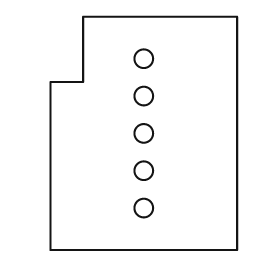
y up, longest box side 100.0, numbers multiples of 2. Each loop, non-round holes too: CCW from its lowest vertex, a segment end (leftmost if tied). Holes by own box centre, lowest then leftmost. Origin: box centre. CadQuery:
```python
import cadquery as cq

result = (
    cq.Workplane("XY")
    .moveTo(-40.0, -50.0)
    .lineTo(40.0, -50.0)
    .lineTo(40.0, 50.0)
    .lineTo(-26.0, 50.0)
    .lineTo(-26.0, 22.0)
    .lineTo(-40.0, 22.0)
    .close()
    .moveTo(0.0, -32.0)
    .circle(4.0)
    .moveTo(0.0, -16.0)
    .circle(4.0)
    .moveTo(0.0, 0.0)
    .circle(4.0)
    .moveTo(0.0, 16.0)
    .circle(4.0)
    .moveTo(0.0, 32.0)
    .circle(4.0)
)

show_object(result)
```